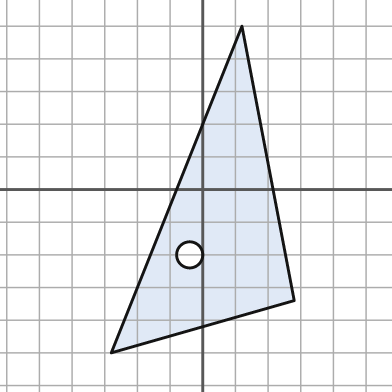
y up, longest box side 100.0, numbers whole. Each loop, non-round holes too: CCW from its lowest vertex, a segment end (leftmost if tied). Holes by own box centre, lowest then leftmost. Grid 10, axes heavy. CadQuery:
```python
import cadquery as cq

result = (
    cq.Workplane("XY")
    .moveTo(-28.0, -50.0)
    .lineTo(28.0, -34.0)
    .lineTo(12.0, 50.0)
    .close()
    .moveTo(-4.0, -20.0)
    .circle(4.0)
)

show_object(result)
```